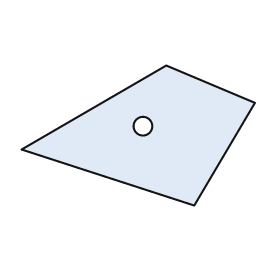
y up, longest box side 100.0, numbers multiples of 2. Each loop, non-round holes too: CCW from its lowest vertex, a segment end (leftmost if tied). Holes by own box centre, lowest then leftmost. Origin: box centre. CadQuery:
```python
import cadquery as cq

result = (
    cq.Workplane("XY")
    .moveTo(24.0, -30.0)
    .lineTo(50.0, 14.0)
    .lineTo(12.0, 30.0)
    .lineTo(-50.0, -6.0)
    .close()
    .moveTo(2.0, 4.0)
    .circle(4.0)
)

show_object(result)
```